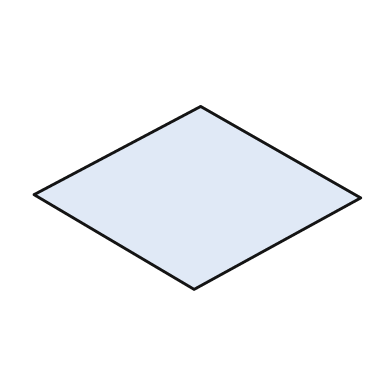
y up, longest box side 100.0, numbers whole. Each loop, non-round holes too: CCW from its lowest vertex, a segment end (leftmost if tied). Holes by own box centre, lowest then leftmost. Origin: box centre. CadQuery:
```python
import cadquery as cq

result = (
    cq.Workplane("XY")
    .moveTo(-1.0, -28.0)
    .lineTo(50.0, 0.0)
    .lineTo(1.0, 28.0)
    .lineTo(-50.0, 1.0)
    .close()
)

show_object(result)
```